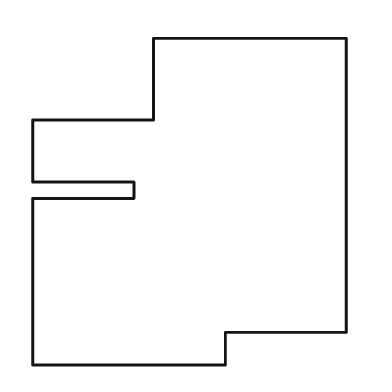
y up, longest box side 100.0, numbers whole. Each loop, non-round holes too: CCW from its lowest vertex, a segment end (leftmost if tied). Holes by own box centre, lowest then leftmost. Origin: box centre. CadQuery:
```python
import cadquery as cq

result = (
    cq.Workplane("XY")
    .moveTo(-48.0, -50.0)
    .lineTo(11.0, -50.0)
    .lineTo(11.0, -40.0)
    .lineTo(48.0, -40.0)
    .lineTo(48.0, 50.0)
    .lineTo(-11.0, 50.0)
    .lineTo(-11.0, 25.0)
    .lineTo(-48.0, 25.0)
    .lineTo(-48.0, 6.0)
    .lineTo(-17.0, 6.0)
    .lineTo(-17.0, 1.0)
    .lineTo(-48.0, 1.0)
    .close()
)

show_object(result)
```